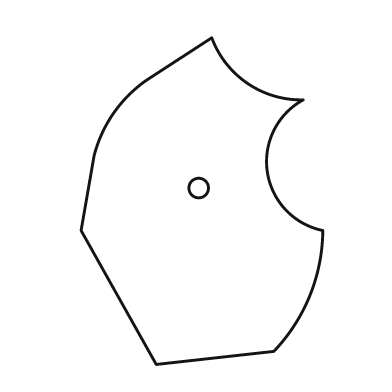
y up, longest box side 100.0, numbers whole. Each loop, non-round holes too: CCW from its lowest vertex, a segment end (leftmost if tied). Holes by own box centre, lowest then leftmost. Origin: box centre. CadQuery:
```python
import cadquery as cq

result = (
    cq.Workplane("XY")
    .moveTo(-14.0, -50.0)
    .lineTo(22.0, -46.0)
    .threePointArc((33.0, -29.0), (37.0, -9.0))
    .threePointArc((20.0, 9.0), (31.0, 31.0))
    .threePointArc((14.0, 36.0), (3.0, 50.0))
    .lineTo(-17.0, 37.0)
    .threePointArc((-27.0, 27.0), (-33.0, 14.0))
    .lineTo(-37.0, -9.0)
    .close()
    .moveTo(-1.0, 4.0)
    .circle(3.0)
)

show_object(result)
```